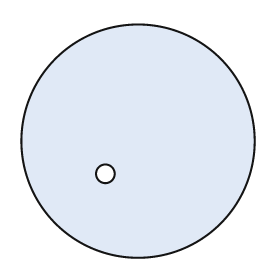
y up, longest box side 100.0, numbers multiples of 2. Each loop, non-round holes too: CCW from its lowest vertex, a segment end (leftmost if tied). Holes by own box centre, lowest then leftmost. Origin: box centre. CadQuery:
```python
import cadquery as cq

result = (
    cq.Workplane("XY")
    .moveTo(0.0, 0.0)
    .circle(50.0)
    .moveTo(-14.0, -14.0)
    .circle(4.0)
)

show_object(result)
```